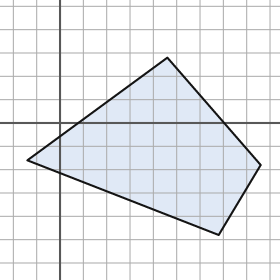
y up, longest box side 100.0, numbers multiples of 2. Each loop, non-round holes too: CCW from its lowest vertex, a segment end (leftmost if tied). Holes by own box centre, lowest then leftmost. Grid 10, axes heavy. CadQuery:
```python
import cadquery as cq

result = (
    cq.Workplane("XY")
    .moveTo(68.0, -48.0)
    .lineTo(86.0, -18.0)
    .lineTo(46.0, 28.0)
    .lineTo(-14.0, -16.0)
    .close()
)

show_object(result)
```